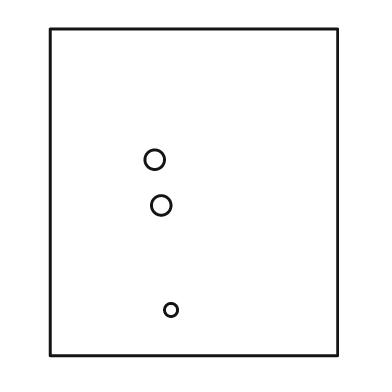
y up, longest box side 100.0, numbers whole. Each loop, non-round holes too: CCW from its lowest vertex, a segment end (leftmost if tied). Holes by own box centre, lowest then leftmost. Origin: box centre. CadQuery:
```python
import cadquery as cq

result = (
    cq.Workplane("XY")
    .moveTo(-44.0, -50.0)
    .lineTo(44.0, -50.0)
    .lineTo(44.0, 50.0)
    .lineTo(-44.0, 50.0)
    .close()
    .moveTo(-7.0, -36.0)
    .circle(2.0)
    .moveTo(-10.0, -4.0)
    .circle(3.0)
    .moveTo(-12.0, 10.0)
    .circle(3.0)
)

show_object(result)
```